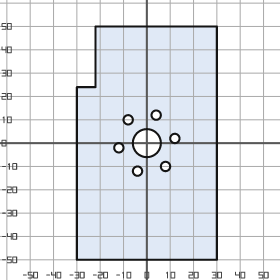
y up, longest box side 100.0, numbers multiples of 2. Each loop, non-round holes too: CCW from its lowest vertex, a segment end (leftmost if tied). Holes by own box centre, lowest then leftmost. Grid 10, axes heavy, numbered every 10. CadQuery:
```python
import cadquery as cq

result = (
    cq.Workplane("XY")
    .moveTo(-30.0, -50.0)
    .lineTo(30.0, -50.0)
    .lineTo(30.0, 50.0)
    .lineTo(-22.0, 50.0)
    .lineTo(-22.0, 24.0)
    .lineTo(-30.0, 24.0)
    .close()
    .moveTo(-4.0, -12.0)
    .circle(2.0)
    .moveTo(8.0, -10.0)
    .circle(2.0)
    .moveTo(-12.0, -2.0)
    .circle(2.0)
    .moveTo(0.0, 0.0)
    .circle(6.0)
    .moveTo(12.0, 2.0)
    .circle(2.0)
    .moveTo(-8.0, 10.0)
    .circle(2.0)
    .moveTo(4.0, 12.0)
    .circle(2.0)
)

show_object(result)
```